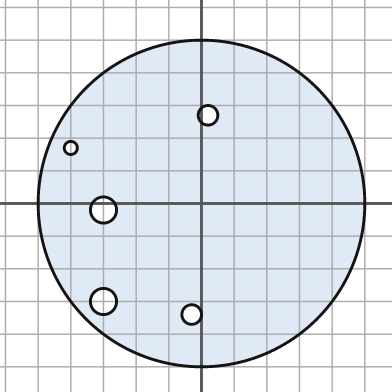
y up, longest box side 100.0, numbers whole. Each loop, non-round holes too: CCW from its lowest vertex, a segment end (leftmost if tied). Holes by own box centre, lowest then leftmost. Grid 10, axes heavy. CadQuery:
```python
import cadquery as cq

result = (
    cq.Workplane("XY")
    .moveTo(0.0, 0.0)
    .circle(50.0)
    .moveTo(-3.0, -34.0)
    .circle(3.0)
    .moveTo(-30.0, -30.0)
    .circle(4.0)
    .moveTo(-30.0, -2.0)
    .circle(4.0)
    .moveTo(-40.0, 17.0)
    .circle(2.0)
    .moveTo(2.0, 27.0)
    .circle(3.0)
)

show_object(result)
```